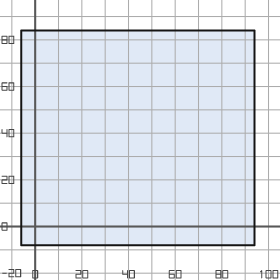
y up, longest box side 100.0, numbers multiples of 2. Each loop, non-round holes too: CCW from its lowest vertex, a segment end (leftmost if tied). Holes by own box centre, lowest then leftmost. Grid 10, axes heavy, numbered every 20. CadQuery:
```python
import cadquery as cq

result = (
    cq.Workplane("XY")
    .moveTo(-6.0, -8.0)
    .lineTo(94.0, -8.0)
    .lineTo(94.0, 84.0)
    .lineTo(-6.0, 84.0)
    .close()
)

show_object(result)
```